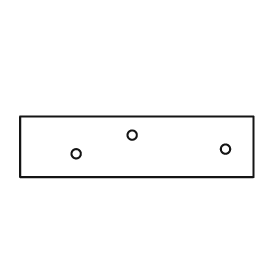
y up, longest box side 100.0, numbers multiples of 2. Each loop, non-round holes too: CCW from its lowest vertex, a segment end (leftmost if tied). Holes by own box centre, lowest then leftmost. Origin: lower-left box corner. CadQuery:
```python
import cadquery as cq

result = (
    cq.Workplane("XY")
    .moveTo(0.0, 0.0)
    .lineTo(100.0, 0.0)
    .lineTo(100.0, 26.0)
    .lineTo(0.0, 26.0)
    .close()
    .moveTo(24.0, 10.0)
    .circle(2.0)
    .moveTo(88.0, 12.0)
    .circle(2.0)
    .moveTo(48.0, 18.0)
    .circle(2.0)
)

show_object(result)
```